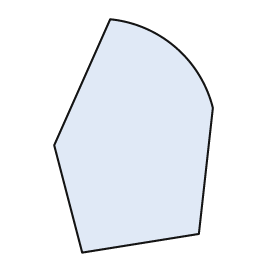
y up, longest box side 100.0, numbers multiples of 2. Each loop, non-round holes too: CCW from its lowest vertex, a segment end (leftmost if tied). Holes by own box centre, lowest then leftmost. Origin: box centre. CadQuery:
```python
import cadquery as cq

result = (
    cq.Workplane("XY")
    .moveTo(-22.0, -50.0)
    .lineTo(28.0, -42.0)
    .lineTo(34.0, 12.0)
    .threePointArc((18.0, 38.0), (-10.0, 50.0))
    .lineTo(-34.0, -4.0)
    .close()
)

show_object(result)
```